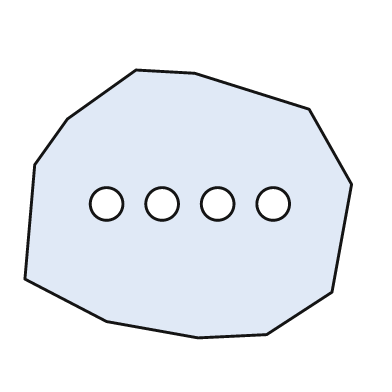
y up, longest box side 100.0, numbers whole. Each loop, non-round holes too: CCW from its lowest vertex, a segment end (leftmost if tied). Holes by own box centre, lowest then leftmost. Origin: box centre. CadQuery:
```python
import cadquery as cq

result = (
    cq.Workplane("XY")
    .moveTo(3.0, -41.0)
    .lineTo(24.0, -40.0)
    .lineTo(44.0, -27.0)
    .lineTo(50.0, 6.0)
    .lineTo(37.0, 29.0)
    .lineTo(2.0, 40.0)
    .lineTo(-16.0, 41.0)
    .lineTo(-37.0, 26.0)
    .lineTo(-47.0, 12.0)
    .lineTo(-50.0, -23.0)
    .lineTo(-25.0, -36.0)
    .close()
    .moveTo(-25.0, 0.0)
    .circle(5.0)
    .moveTo(-8.0, 0.0)
    .circle(5.0)
    .moveTo(9.0, 0.0)
    .circle(5.0)
    .moveTo(26.0, 0.0)
    .circle(5.0)
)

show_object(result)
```